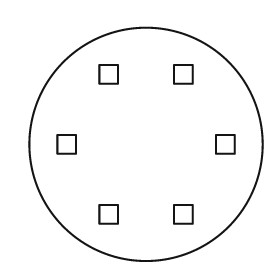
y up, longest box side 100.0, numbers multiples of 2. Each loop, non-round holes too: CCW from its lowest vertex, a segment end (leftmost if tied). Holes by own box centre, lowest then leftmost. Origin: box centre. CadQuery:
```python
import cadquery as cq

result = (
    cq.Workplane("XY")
    .moveTo(0.0, 0.0)
    .circle(50.0)
    .moveTo(-20.0, -34.0)
    .lineTo(-12.0, -34.0)
    .lineTo(-12.0, -26.0)
    .lineTo(-20.0, -26.0)
    .close()
    .moveTo(12.0, -34.0)
    .lineTo(20.0, -34.0)
    .lineTo(20.0, -26.0)
    .lineTo(12.0, -26.0)
    .close()
    .moveTo(-38.0, -4.0)
    .lineTo(-30.0, -4.0)
    .lineTo(-30.0, 4.0)
    .lineTo(-38.0, 4.0)
    .close()
    .moveTo(30.0, -4.0)
    .lineTo(38.0, -4.0)
    .lineTo(38.0, 4.0)
    .lineTo(30.0, 4.0)
    .close()
    .moveTo(-20.0, 26.0)
    .lineTo(-12.0, 26.0)
    .lineTo(-12.0, 34.0)
    .lineTo(-20.0, 34.0)
    .close()
    .moveTo(12.0, 26.0)
    .lineTo(20.0, 26.0)
    .lineTo(20.0, 34.0)
    .lineTo(12.0, 34.0)
    .close()
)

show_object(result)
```